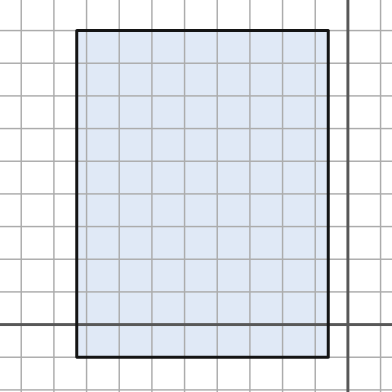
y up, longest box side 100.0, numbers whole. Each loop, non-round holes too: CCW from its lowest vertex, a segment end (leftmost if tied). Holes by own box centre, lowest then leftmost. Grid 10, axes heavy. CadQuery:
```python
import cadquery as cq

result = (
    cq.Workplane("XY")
    .moveTo(-83.0, -10.0)
    .lineTo(-6.0, -10.0)
    .lineTo(-6.0, 90.0)
    .lineTo(-83.0, 90.0)
    .close()
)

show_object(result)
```